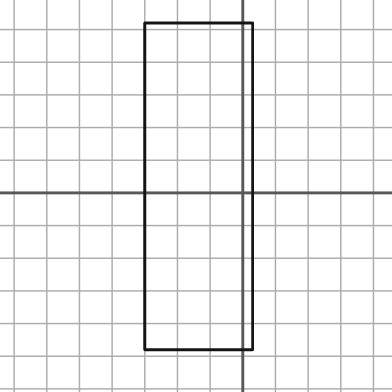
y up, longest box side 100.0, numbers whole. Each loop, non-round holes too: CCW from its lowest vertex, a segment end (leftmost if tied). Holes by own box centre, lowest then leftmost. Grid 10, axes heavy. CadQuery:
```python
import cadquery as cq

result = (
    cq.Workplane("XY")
    .moveTo(-30.0, -48.0)
    .lineTo(3.0, -48.0)
    .lineTo(3.0, 52.0)
    .lineTo(-30.0, 52.0)
    .close()
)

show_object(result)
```